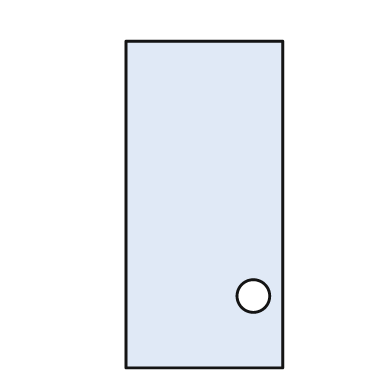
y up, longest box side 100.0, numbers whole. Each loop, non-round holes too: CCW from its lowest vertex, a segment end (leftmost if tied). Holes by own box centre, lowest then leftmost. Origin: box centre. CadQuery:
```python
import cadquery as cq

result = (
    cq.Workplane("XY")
    .moveTo(-24.0, -50.0)
    .lineTo(24.0, -50.0)
    .lineTo(24.0, 50.0)
    .lineTo(-24.0, 50.0)
    .close()
    .moveTo(15.0, -28.0)
    .circle(5.0)
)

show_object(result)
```